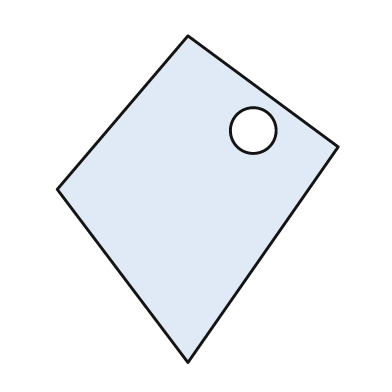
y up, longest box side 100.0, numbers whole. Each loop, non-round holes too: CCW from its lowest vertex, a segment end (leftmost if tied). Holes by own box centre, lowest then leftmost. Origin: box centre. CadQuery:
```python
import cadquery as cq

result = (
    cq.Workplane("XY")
    .moveTo(-3.0, -50.0)
    .lineTo(43.0, 16.0)
    .lineTo(-3.0, 50.0)
    .lineTo(-43.0, 3.0)
    .close()
    .moveTo(17.0, 21.0)
    .circle(7.0)
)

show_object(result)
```